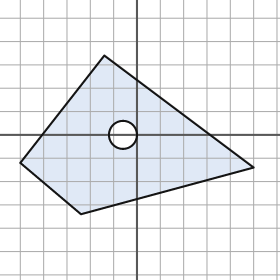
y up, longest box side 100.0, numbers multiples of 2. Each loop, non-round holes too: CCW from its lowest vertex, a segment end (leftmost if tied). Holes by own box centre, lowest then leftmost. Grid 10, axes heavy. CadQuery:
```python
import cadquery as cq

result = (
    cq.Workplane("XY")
    .moveTo(-24.0, -34.0)
    .lineTo(50.0, -14.0)
    .lineTo(-14.0, 34.0)
    .lineTo(-50.0, -12.0)
    .close()
    .moveTo(-6.0, 0.0)
    .circle(6.0)
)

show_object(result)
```